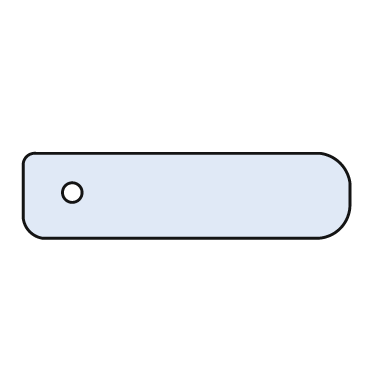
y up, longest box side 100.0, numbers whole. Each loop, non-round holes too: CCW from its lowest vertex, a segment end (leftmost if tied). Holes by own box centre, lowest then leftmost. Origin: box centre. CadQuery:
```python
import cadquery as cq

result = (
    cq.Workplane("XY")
    .moveTo(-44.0, -13.0)
    .lineTo(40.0, -13.0)
    .threePointArc((47.0, -10.0), (50.0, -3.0))
    .lineTo(50.0, 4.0)
    .threePointArc((47.0, 10.0), (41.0, 13.0))
    .lineTo(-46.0, 13.0)
    .threePointArc((-49.0, 12.0), (-50.0, 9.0))
    .lineTo(-50.0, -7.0)
    .threePointArc((-48.0, -11.0), (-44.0, -13.0))
    .close()
    .moveTo(-35.0, 1.0)
    .circle(3.0)
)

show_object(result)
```